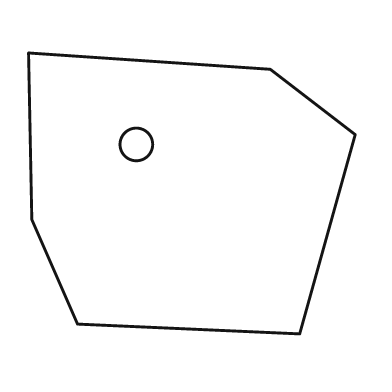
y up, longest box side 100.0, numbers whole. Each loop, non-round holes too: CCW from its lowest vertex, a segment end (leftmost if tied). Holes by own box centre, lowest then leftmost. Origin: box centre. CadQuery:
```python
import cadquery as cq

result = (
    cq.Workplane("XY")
    .moveTo(33.0, -43.0)
    .lineTo(50.0, 18.0)
    .lineTo(24.0, 38.0)
    .lineTo(-50.0, 43.0)
    .lineTo(-49.0, -8.0)
    .lineTo(-35.0, -40.0)
    .close()
    .moveTo(-17.0, 15.0)
    .circle(5.0)
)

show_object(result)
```